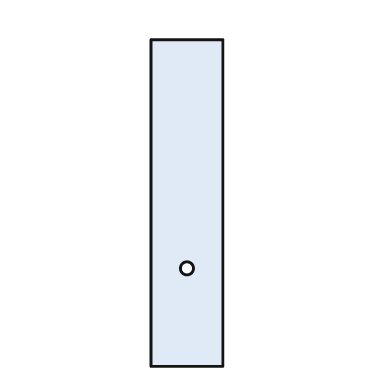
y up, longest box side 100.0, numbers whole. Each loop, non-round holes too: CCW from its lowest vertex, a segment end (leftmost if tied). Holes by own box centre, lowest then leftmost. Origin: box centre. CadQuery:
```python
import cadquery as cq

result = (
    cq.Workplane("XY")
    .moveTo(-11.0, -50.0)
    .lineTo(11.0, -50.0)
    .lineTo(11.0, 50.0)
    .lineTo(-11.0, 50.0)
    .close()
    .moveTo(0.0, -20.0)
    .circle(2.0)
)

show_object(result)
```